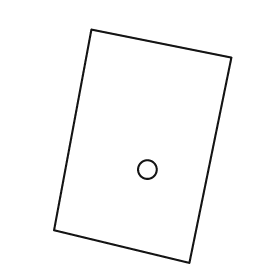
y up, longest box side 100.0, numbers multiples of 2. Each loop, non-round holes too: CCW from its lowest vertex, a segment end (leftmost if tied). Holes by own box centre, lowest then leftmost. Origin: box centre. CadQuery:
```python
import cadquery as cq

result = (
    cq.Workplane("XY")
    .moveTo(20.0, -50.0)
    .lineTo(38.0, 38.0)
    .lineTo(-22.0, 50.0)
    .lineTo(-38.0, -36.0)
    .close()
    .moveTo(2.0, -10.0)
    .circle(4.0)
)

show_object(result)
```